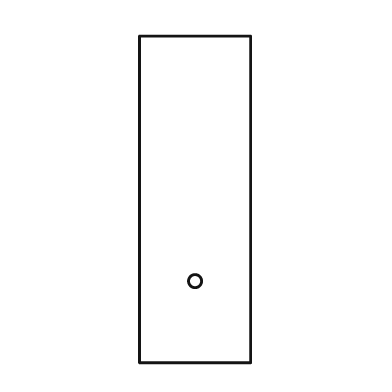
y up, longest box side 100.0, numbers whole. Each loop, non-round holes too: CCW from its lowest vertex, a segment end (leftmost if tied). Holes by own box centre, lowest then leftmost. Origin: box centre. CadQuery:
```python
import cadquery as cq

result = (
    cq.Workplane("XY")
    .moveTo(-17.0, -50.0)
    .lineTo(17.0, -50.0)
    .lineTo(17.0, 50.0)
    .lineTo(-17.0, 50.0)
    .close()
    .moveTo(0.0, -25.0)
    .circle(2.0)
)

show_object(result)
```